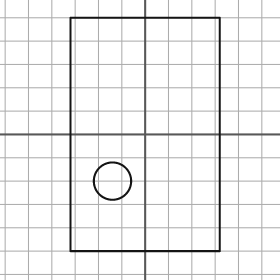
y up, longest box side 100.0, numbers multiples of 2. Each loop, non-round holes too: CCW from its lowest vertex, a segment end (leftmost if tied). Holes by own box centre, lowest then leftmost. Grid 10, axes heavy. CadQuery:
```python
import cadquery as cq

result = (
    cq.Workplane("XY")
    .moveTo(-32.0, -50.0)
    .lineTo(32.0, -50.0)
    .lineTo(32.0, 50.0)
    .lineTo(-32.0, 50.0)
    .close()
    .moveTo(-14.0, -20.0)
    .circle(8.0)
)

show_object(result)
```